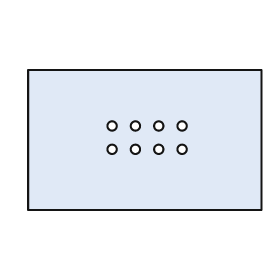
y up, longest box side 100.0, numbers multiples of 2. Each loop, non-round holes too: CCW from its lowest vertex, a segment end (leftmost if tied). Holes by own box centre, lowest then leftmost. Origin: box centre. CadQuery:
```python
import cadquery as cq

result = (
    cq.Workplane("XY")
    .moveTo(-50.0, -30.0)
    .lineTo(50.0, -30.0)
    .lineTo(50.0, 30.0)
    .lineTo(-50.0, 30.0)
    .close()
    .moveTo(-14.0, -4.0)
    .circle(2.0)
    .moveTo(-4.0, -4.0)
    .circle(2.0)
    .moveTo(6.0, -4.0)
    .circle(2.0)
    .moveTo(16.0, -4.0)
    .circle(2.0)
    .moveTo(-14.0, 6.0)
    .circle(2.0)
    .moveTo(-4.0, 6.0)
    .circle(2.0)
    .moveTo(6.0, 6.0)
    .circle(2.0)
    .moveTo(16.0, 6.0)
    .circle(2.0)
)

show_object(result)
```